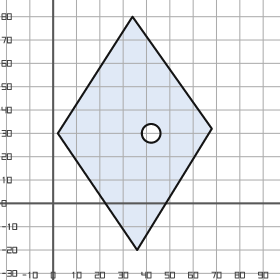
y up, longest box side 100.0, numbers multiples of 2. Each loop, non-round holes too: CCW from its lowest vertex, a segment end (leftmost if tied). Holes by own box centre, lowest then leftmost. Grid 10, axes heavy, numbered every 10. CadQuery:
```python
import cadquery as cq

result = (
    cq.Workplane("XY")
    .moveTo(36.0, -20.0)
    .lineTo(68.0, 32.0)
    .lineTo(34.0, 80.0)
    .lineTo(2.0, 30.0)
    .close()
    .moveTo(42.0, 30.0)
    .circle(4.0)
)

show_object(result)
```